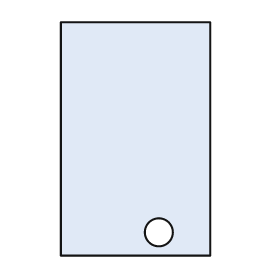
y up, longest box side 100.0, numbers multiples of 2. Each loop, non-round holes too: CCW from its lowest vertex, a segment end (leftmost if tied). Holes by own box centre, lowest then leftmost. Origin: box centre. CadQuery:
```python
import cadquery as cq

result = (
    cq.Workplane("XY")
    .moveTo(-32.0, -50.0)
    .lineTo(32.0, -50.0)
    .lineTo(32.0, 50.0)
    .lineTo(-32.0, 50.0)
    .close()
    .moveTo(10.0, -40.0)
    .circle(6.0)
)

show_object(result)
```